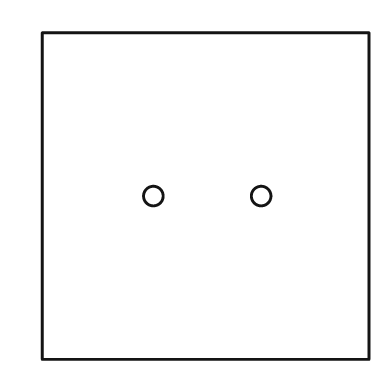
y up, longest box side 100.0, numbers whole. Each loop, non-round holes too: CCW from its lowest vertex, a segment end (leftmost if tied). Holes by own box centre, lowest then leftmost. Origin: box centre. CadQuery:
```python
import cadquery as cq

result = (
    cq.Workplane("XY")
    .moveTo(-50.0, -50.0)
    .lineTo(50.0, -50.0)
    .lineTo(50.0, 50.0)
    .lineTo(-50.0, 50.0)
    .close()
    .moveTo(-16.0, 0.0)
    .circle(3.0)
    .moveTo(17.0, 0.0)
    .circle(3.0)
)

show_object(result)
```